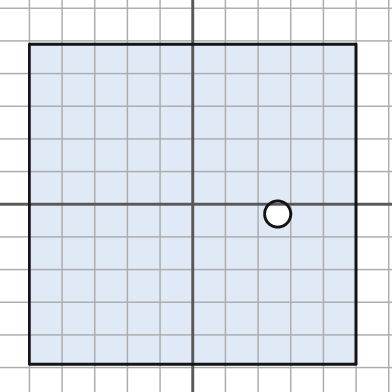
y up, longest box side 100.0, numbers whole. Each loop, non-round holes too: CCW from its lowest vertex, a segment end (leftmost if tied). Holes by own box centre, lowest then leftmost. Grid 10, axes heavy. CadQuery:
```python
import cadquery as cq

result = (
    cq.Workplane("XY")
    .moveTo(-50.0, -49.0)
    .lineTo(50.0, -49.0)
    .lineTo(50.0, 49.0)
    .lineTo(-50.0, 49.0)
    .close()
    .moveTo(26.0, -3.0)
    .circle(4.0)
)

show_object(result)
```